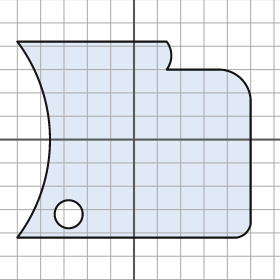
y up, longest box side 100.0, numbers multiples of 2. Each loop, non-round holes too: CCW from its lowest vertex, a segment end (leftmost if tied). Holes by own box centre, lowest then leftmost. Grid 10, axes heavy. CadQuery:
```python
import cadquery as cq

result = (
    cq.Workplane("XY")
    .moveTo(-50.0, -42.0)
    .lineTo(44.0, -42.0)
    .threePointArc((48.0, -40.0), (50.0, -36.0))
    .lineTo(50.0, 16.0)
    .threePointArc((46.0, 26.0), (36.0, 30.0))
    .lineTo(14.0, 30.0)
    .threePointArc((16.0, 36.0), (14.0, 42.0))
    .lineTo(-50.0, 42.0)
    .threePointArc((-36.0, 0.0), (-50.0, -42.0))
    .close()
    .moveTo(-28.0, -32.0)
    .circle(6.0)
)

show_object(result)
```